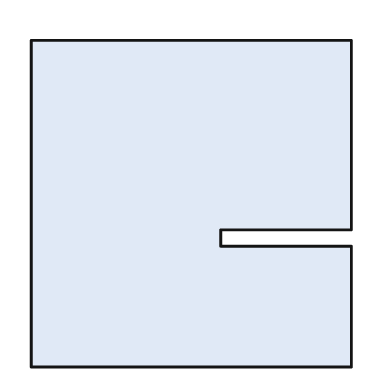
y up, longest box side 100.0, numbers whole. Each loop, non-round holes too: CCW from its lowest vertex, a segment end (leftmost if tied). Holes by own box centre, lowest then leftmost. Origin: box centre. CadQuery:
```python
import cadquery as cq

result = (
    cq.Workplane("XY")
    .moveTo(-49.0, -50.0)
    .lineTo(49.0, -50.0)
    .lineTo(49.0, -13.0)
    .lineTo(9.0, -13.0)
    .lineTo(9.0, -8.0)
    .lineTo(49.0, -8.0)
    .lineTo(49.0, 50.0)
    .lineTo(-49.0, 50.0)
    .close()
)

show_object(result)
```